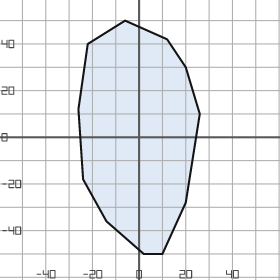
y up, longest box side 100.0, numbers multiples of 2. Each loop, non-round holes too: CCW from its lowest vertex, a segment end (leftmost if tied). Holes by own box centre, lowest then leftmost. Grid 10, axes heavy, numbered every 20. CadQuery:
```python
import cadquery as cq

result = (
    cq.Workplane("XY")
    .moveTo(2.0, -50.0)
    .lineTo(10.0, -50.0)
    .lineTo(20.0, -28.0)
    .lineTo(26.0, 10.0)
    .lineTo(20.0, 30.0)
    .lineTo(12.0, 42.0)
    .lineTo(-6.0, 50.0)
    .lineTo(-22.0, 40.0)
    .lineTo(-26.0, 12.0)
    .lineTo(-24.0, -18.0)
    .lineTo(-14.0, -36.0)
    .close()
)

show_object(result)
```